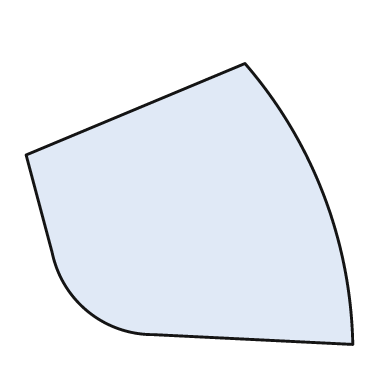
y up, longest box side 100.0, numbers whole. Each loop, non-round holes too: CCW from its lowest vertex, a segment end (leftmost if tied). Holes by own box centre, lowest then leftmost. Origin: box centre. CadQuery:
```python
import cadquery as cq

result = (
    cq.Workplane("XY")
    .moveTo(50.0, -43.0)
    .threePointArc((41.0, 3.0), (17.0, 43.0))
    .lineTo(-50.0, 15.0)
    .lineTo(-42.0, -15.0)
    .threePointArc((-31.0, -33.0), (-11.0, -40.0))
    .close()
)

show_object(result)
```